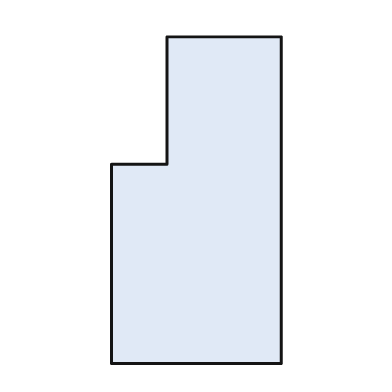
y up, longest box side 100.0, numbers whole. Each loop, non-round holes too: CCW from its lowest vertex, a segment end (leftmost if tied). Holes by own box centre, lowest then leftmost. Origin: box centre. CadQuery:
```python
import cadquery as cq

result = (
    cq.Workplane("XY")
    .moveTo(-26.0, -50.0)
    .lineTo(26.0, -50.0)
    .lineTo(26.0, 50.0)
    .lineTo(-9.0, 50.0)
    .lineTo(-9.0, 11.0)
    .lineTo(-26.0, 11.0)
    .close()
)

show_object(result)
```